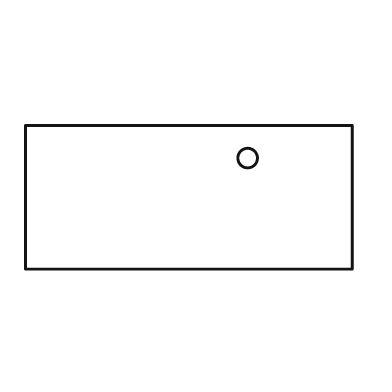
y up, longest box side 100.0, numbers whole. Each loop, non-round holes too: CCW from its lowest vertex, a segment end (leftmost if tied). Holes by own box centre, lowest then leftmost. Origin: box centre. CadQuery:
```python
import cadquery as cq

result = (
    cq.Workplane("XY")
    .moveTo(-50.0, -22.0)
    .lineTo(50.0, -22.0)
    .lineTo(50.0, 22.0)
    .lineTo(-50.0, 22.0)
    .close()
    .moveTo(18.0, 12.0)
    .circle(3.0)
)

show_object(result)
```